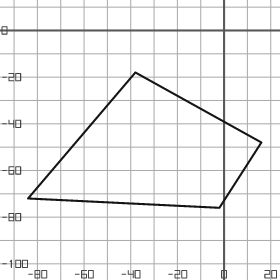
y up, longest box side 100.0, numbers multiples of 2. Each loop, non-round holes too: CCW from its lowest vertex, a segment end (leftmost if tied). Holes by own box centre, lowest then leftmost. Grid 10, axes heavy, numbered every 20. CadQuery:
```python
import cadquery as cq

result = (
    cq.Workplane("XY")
    .moveTo(-2.0, -76.0)
    .lineTo(16.0, -48.0)
    .lineTo(-38.0, -18.0)
    .lineTo(-84.0, -72.0)
    .close()
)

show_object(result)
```